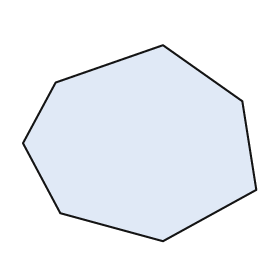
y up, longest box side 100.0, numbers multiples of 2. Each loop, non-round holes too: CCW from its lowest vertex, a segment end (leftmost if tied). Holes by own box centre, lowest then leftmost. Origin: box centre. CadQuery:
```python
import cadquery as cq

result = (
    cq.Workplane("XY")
    .moveTo(10.0, -42.0)
    .lineTo(50.0, -20.0)
    .lineTo(44.0, 18.0)
    .lineTo(10.0, 42.0)
    .lineTo(-36.0, 26.0)
    .lineTo(-50.0, 0.0)
    .lineTo(-34.0, -30.0)
    .close()
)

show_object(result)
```